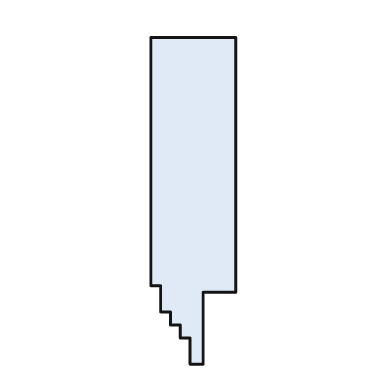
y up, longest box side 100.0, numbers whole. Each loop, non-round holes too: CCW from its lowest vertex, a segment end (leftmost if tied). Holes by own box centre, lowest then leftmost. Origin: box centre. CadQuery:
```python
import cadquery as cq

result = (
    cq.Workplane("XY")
    .moveTo(-1.0, -50.0)
    .lineTo(3.0, -50.0)
    .lineTo(3.0, -28.0)
    .lineTo(13.0, -28.0)
    .lineTo(13.0, 50.0)
    .lineTo(-13.0, 50.0)
    .lineTo(-13.0, -26.0)
    .lineTo(-10.0, -26.0)
    .lineTo(-10.0, -34.0)
    .lineTo(-7.0, -34.0)
    .lineTo(-7.0, -38.0)
    .lineTo(-4.0, -38.0)
    .lineTo(-4.0, -42.0)
    .lineTo(-1.0, -42.0)
    .close()
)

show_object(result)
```